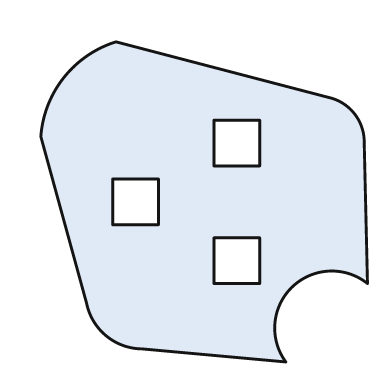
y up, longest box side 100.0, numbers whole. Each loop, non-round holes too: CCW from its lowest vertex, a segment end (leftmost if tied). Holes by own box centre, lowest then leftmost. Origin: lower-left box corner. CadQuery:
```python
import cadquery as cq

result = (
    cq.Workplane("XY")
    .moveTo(75.0, 0.0)
    .threePointArc((77.0, 23.0), (100.0, 24.0))
    .lineTo(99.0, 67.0)
    .threePointArc((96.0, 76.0), (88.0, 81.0))
    .lineTo(23.0, 98.0)
    .threePointArc((7.0, 87.0), (0.0, 69.0))
    .lineTo(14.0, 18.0)
    .threePointArc((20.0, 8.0), (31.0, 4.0))
    .close()
    .moveTo(53.0, 24.0)
    .lineTo(67.0, 24.0)
    .lineTo(67.0, 38.0)
    .lineTo(53.0, 38.0)
    .close()
    .moveTo(22.0, 42.0)
    .lineTo(36.0, 42.0)
    .lineTo(36.0, 56.0)
    .lineTo(22.0, 56.0)
    .close()
    .moveTo(53.0, 60.0)
    .lineTo(67.0, 60.0)
    .lineTo(67.0, 74.0)
    .lineTo(53.0, 74.0)
    .close()
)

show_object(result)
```